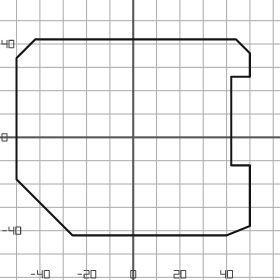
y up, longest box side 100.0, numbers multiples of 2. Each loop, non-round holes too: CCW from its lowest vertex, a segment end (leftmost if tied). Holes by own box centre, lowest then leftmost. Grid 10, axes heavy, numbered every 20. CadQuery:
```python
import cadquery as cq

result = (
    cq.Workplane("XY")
    .moveTo(-26.0, -42.0)
    .lineTo(40.0, -42.0)
    .lineTo(50.0, -38.0)
    .lineTo(50.0, -12.0)
    .lineTo(42.0, -12.0)
    .lineTo(42.0, 26.0)
    .lineTo(50.0, 26.0)
    .lineTo(50.0, 36.0)
    .lineTo(44.0, 42.0)
    .lineTo(-42.0, 42.0)
    .lineTo(-50.0, 34.0)
    .lineTo(-50.0, -18.0)
    .close()
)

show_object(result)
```